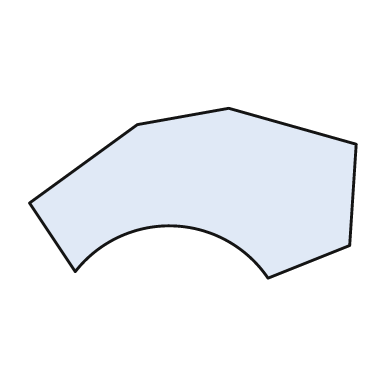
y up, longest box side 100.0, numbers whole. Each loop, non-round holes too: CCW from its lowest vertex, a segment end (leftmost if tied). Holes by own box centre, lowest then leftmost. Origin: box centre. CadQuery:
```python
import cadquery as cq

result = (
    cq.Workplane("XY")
    .moveTo(23.0, -26.0)
    .lineTo(48.0, -16.0)
    .lineTo(50.0, 15.0)
    .lineTo(11.0, 26.0)
    .lineTo(-17.0, 21.0)
    .lineTo(-50.0, -3.0)
    .lineTo(-36.0, -24.0)
    .threePointArc((-6.0, -10.0), (23.0, -26.0))
    .close()
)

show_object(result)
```